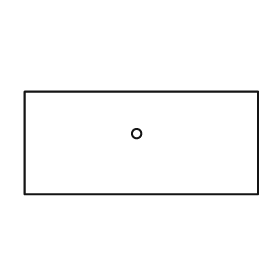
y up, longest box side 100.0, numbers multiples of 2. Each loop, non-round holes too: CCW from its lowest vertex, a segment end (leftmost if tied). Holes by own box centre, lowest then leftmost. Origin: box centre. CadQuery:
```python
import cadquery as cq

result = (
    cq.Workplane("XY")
    .moveTo(-50.0, -22.0)
    .lineTo(50.0, -22.0)
    .lineTo(50.0, 22.0)
    .lineTo(-50.0, 22.0)
    .close()
    .moveTo(-2.0, 4.0)
    .circle(2.0)
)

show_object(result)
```